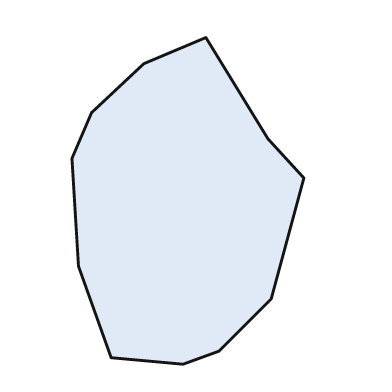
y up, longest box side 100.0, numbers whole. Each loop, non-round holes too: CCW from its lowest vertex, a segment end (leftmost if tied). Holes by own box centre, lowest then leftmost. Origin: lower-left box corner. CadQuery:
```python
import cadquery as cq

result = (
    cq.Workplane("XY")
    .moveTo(34.0, 0.0)
    .lineTo(45.0, 4.0)
    .lineTo(61.0, 20.0)
    .lineTo(71.0, 57.0)
    .lineTo(60.0, 69.0)
    .lineTo(41.0, 100.0)
    .lineTo(22.0, 92.0)
    .lineTo(6.0, 77.0)
    .lineTo(0.0, 63.0)
    .lineTo(2.0, 30.0)
    .lineTo(12.0, 2.0)
    .close()
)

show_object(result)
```